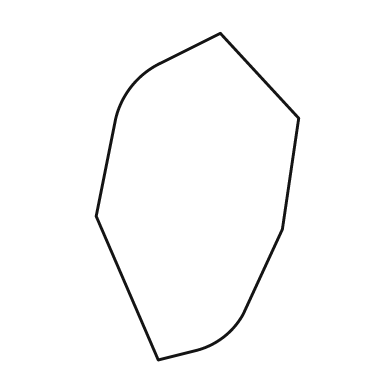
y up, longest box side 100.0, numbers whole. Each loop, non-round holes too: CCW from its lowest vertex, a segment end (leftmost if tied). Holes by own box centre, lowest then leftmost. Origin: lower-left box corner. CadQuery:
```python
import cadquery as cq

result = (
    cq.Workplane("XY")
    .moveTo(19.0, 0.0)
    .lineTo(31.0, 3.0)
    .threePointArc((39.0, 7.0), (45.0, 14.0))
    .lineTo(57.0, 40.0)
    .lineTo(62.0, 74.0)
    .lineTo(38.0, 100.0)
    .lineTo(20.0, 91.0)
    .threePointArc((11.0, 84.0), (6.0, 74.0))
    .lineTo(0.0, 44.0)
    .close()
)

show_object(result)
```